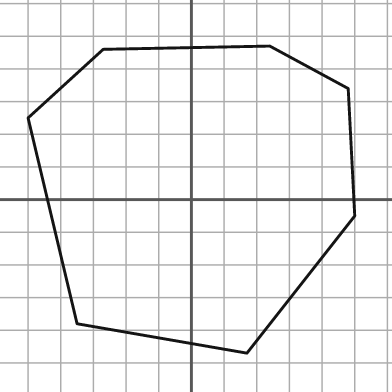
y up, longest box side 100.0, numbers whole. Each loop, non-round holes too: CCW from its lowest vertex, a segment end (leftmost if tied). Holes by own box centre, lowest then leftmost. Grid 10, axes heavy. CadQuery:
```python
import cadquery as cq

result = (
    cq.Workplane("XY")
    .moveTo(17.0, -47.0)
    .lineTo(50.0, -5.0)
    .lineTo(48.0, 34.0)
    .lineTo(24.0, 47.0)
    .lineTo(-27.0, 46.0)
    .lineTo(-50.0, 25.0)
    .lineTo(-35.0, -38.0)
    .close()
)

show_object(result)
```